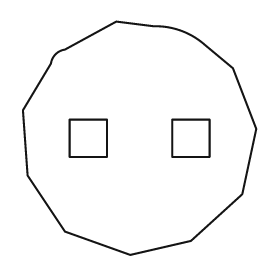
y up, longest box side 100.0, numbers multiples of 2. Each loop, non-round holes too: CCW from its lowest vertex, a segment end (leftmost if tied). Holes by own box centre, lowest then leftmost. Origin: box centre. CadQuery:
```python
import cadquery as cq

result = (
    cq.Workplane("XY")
    .moveTo(-4.0, -50.0)
    .lineTo(22.0, -44.0)
    .lineTo(44.0, -24.0)
    .lineTo(50.0, 4.0)
    .lineTo(40.0, 30.0)
    .lineTo(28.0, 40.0)
    .threePointArc((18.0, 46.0), (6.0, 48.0))
    .lineTo(-10.0, 50.0)
    .lineTo(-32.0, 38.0)
    .threePointArc((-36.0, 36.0), (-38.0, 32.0))
    .lineTo(-50.0, 12.0)
    .lineTo(-48.0, -16.0)
    .lineTo(-32.0, -40.0)
    .close()
    .moveTo(-30.0, -8.0)
    .lineTo(-14.0, -8.0)
    .lineTo(-14.0, 8.0)
    .lineTo(-30.0, 8.0)
    .close()
    .moveTo(14.0, -8.0)
    .lineTo(30.0, -8.0)
    .lineTo(30.0, 8.0)
    .lineTo(14.0, 8.0)
    .close()
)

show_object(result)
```